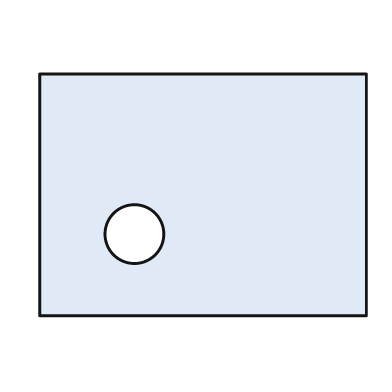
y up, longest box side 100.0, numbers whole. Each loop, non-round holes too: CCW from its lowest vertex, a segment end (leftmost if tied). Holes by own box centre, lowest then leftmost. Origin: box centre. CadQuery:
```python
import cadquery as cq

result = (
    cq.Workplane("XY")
    .moveTo(-50.0, -37.0)
    .lineTo(50.0, -37.0)
    .lineTo(50.0, 37.0)
    .lineTo(-50.0, 37.0)
    .close()
    .moveTo(-21.0, -12.0)
    .circle(9.0)
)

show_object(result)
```